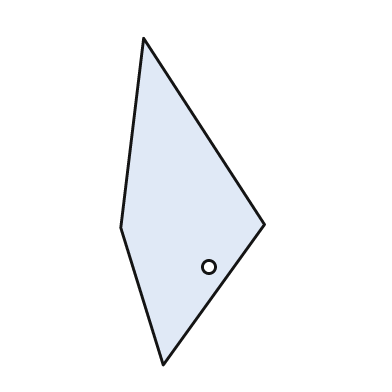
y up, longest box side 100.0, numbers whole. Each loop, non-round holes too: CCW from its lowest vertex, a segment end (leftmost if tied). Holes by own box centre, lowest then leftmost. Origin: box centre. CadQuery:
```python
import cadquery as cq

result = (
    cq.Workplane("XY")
    .moveTo(-9.0, -50.0)
    .lineTo(22.0, -7.0)
    .lineTo(-15.0, 50.0)
    .lineTo(-22.0, -8.0)
    .close()
    .moveTo(5.0, -20.0)
    .circle(2.0)
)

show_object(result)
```